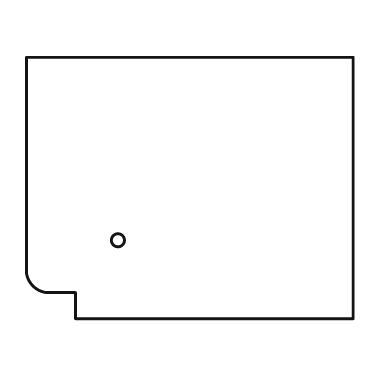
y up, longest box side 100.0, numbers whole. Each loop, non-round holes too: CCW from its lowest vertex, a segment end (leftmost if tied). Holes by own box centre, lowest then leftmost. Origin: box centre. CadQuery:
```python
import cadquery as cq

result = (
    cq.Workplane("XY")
    .moveTo(-35.0, -40.0)
    .lineTo(50.0, -40.0)
    .lineTo(50.0, 40.0)
    .lineTo(-50.0, 40.0)
    .lineTo(-50.0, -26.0)
    .threePointArc((-48.0, -30.0), (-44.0, -32.0))
    .lineTo(-35.0, -32.0)
    .close()
    .moveTo(-22.0, -16.0)
    .circle(2.0)
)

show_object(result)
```